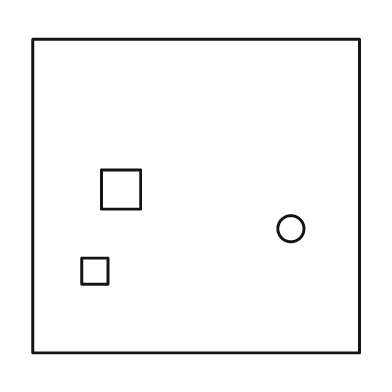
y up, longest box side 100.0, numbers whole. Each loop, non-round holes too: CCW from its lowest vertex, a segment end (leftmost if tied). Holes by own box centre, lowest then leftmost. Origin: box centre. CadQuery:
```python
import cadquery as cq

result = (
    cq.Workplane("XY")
    .moveTo(-50.0, -48.0)
    .lineTo(50.0, -48.0)
    .lineTo(50.0, 48.0)
    .lineTo(-50.0, 48.0)
    .close()
    .moveTo(-35.0, -27.0)
    .lineTo(-27.0, -27.0)
    .lineTo(-27.0, -19.0)
    .lineTo(-35.0, -19.0)
    .close()
    .moveTo(29.0, -10.0)
    .circle(4.0)
    .moveTo(-29.0, -4.0)
    .lineTo(-17.0, -4.0)
    .lineTo(-17.0, 8.0)
    .lineTo(-29.0, 8.0)
    .close()
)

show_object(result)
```